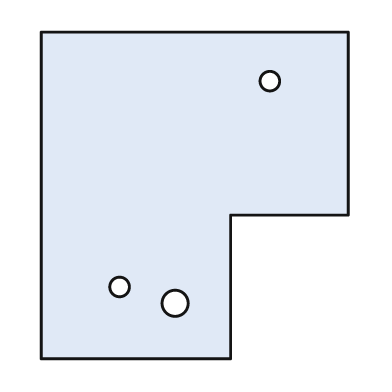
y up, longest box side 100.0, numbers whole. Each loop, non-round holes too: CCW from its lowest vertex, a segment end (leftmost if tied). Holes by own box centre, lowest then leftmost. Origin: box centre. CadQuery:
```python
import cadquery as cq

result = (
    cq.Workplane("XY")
    .moveTo(-47.0, -50.0)
    .lineTo(11.0, -50.0)
    .lineTo(11.0, -6.0)
    .lineTo(47.0, -6.0)
    .lineTo(47.0, 50.0)
    .lineTo(-47.0, 50.0)
    .close()
    .moveTo(-6.0, -33.0)
    .circle(4.0)
    .moveTo(-23.0, -28.0)
    .circle(3.0)
    .moveTo(23.0, 35.0)
    .circle(3.0)
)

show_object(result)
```